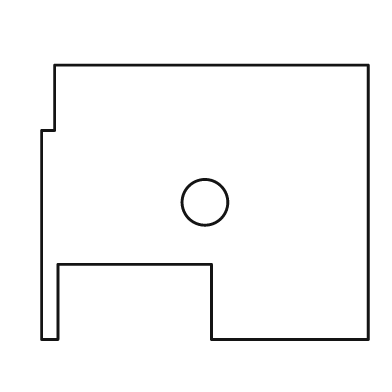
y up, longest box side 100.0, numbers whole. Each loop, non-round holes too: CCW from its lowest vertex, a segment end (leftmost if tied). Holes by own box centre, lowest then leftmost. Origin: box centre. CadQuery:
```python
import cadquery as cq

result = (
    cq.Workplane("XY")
    .moveTo(-50.0, -42.0)
    .lineTo(-45.0, -42.0)
    .lineTo(-45.0, -19.0)
    .lineTo(2.0, -19.0)
    .lineTo(2.0, -42.0)
    .lineTo(50.0, -42.0)
    .lineTo(50.0, 42.0)
    .lineTo(-46.0, 42.0)
    .lineTo(-46.0, 22.0)
    .lineTo(-50.0, 22.0)
    .close()
    .moveTo(0.0, 0.0)
    .circle(7.0)
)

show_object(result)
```